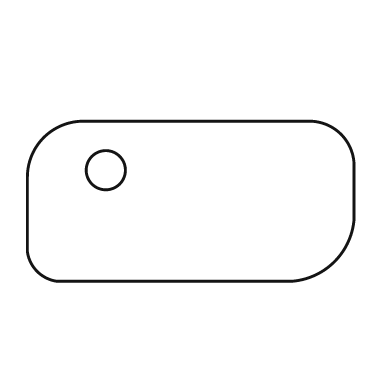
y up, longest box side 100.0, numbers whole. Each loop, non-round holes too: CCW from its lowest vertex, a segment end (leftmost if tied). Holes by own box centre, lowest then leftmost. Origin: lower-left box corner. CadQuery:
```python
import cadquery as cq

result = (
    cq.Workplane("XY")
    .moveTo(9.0, 0.0)
    .lineTo(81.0, 0.0)
    .threePointArc((94.0, 6.0), (100.0, 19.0))
    .lineTo(100.0, 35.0)
    .threePointArc((96.0, 45.0), (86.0, 49.0))
    .lineTo(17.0, 49.0)
    .threePointArc((5.0, 44.0), (0.0, 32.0))
    .lineTo(0.0, 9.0)
    .threePointArc((3.0, 3.0), (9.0, 0.0))
    .close()
    .moveTo(24.0, 34.0)
    .circle(6.0)
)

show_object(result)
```